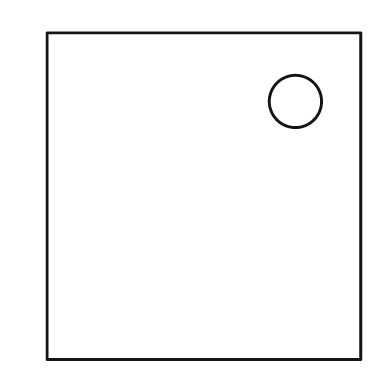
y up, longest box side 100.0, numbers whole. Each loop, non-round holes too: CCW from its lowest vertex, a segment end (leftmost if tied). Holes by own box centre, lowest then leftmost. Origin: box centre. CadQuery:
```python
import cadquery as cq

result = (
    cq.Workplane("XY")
    .moveTo(-48.0, -50.0)
    .lineTo(48.0, -50.0)
    .lineTo(48.0, 50.0)
    .lineTo(-48.0, 50.0)
    .close()
    .moveTo(28.0, 29.0)
    .circle(8.0)
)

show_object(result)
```